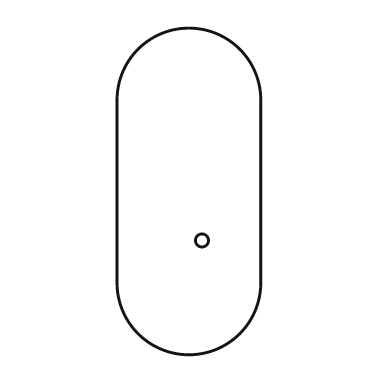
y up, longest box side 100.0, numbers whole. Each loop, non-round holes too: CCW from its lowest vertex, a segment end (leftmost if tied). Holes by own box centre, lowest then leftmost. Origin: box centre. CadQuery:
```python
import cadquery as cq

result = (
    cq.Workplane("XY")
    .moveTo(-22.0, -28.0)
    .threePointArc((0.0, -50.0), (22.0, -28.0))
    .lineTo(22.0, 28.0)
    .threePointArc((0.0, 50.0), (-22.0, 28.0))
    .close()
    .moveTo(4.0, -15.0)
    .circle(2.0)
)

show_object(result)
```